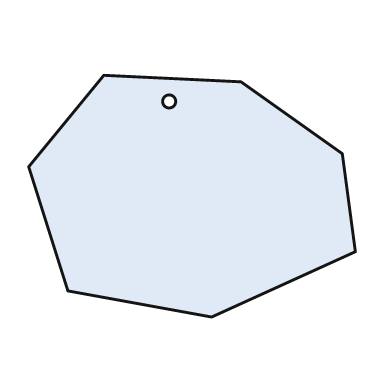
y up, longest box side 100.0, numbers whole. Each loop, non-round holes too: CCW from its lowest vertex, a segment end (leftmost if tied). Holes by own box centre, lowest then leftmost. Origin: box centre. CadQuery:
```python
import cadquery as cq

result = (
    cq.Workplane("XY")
    .moveTo(6.0, -37.0)
    .lineTo(50.0, -17.0)
    .lineTo(46.0, 13.0)
    .lineTo(15.0, 35.0)
    .lineTo(-27.0, 37.0)
    .lineTo(-50.0, 9.0)
    .lineTo(-38.0, -29.0)
    .close()
    .moveTo(-7.0, 29.0)
    .circle(2.0)
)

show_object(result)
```